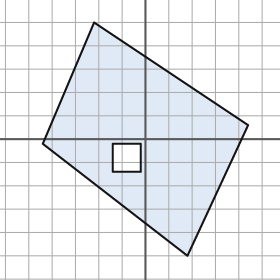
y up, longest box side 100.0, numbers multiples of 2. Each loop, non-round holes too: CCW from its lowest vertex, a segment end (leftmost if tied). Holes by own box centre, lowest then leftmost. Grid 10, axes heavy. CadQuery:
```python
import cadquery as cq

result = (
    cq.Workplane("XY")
    .moveTo(18.0, -50.0)
    .lineTo(44.0, 6.0)
    .lineTo(-22.0, 50.0)
    .lineTo(-44.0, -2.0)
    .close()
    .moveTo(-14.0, -14.0)
    .lineTo(-2.0, -14.0)
    .lineTo(-2.0, -2.0)
    .lineTo(-14.0, -2.0)
    .close()
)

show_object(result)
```